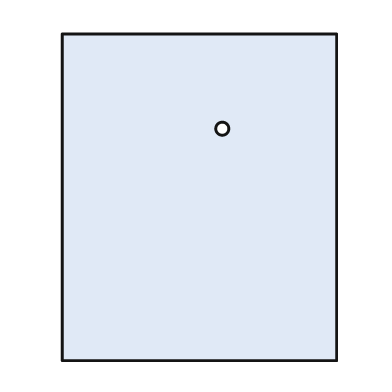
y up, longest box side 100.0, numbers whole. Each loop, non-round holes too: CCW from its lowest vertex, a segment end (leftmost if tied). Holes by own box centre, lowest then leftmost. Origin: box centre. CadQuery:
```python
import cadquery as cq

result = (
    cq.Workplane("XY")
    .moveTo(-42.0, -50.0)
    .lineTo(42.0, -50.0)
    .lineTo(42.0, 50.0)
    .lineTo(-42.0, 50.0)
    .close()
    .moveTo(7.0, 21.0)
    .circle(2.0)
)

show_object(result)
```